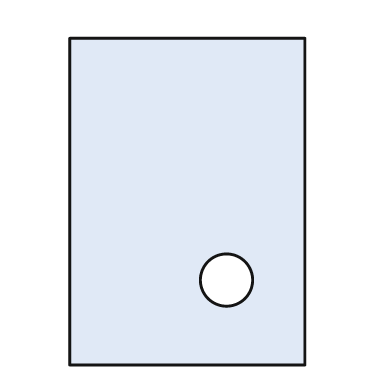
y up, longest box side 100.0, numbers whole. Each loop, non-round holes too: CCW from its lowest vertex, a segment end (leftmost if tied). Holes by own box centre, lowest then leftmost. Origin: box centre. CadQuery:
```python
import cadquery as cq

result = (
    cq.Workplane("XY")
    .moveTo(-36.0, -50.0)
    .lineTo(36.0, -50.0)
    .lineTo(36.0, 50.0)
    .lineTo(-36.0, 50.0)
    .close()
    .moveTo(12.0, -24.0)
    .circle(8.0)
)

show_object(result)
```